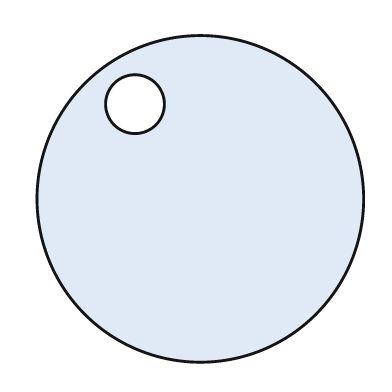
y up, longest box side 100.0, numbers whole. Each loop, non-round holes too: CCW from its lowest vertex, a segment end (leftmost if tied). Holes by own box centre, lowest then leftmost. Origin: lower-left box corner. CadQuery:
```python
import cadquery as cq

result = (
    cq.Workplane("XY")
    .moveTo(50.0, 50.0)
    .circle(50.0)
    .moveTo(30.0, 79.0)
    .circle(9.0)
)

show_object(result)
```